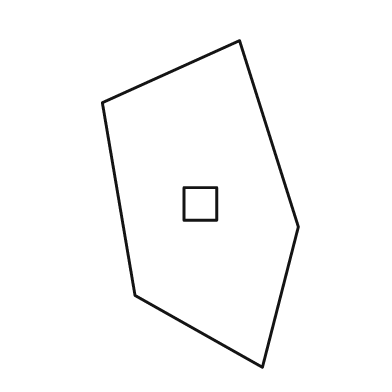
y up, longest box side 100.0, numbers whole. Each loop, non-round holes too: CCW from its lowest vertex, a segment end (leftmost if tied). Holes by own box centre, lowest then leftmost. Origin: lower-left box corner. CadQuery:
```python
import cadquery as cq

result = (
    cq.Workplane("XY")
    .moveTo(49.0, 0.0)
    .lineTo(60.0, 43.0)
    .lineTo(42.0, 100.0)
    .lineTo(0.0, 81.0)
    .lineTo(10.0, 22.0)
    .close()
    .moveTo(25.0, 45.0)
    .lineTo(35.0, 45.0)
    .lineTo(35.0, 55.0)
    .lineTo(25.0, 55.0)
    .close()
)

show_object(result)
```